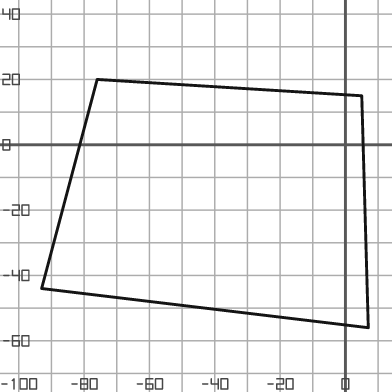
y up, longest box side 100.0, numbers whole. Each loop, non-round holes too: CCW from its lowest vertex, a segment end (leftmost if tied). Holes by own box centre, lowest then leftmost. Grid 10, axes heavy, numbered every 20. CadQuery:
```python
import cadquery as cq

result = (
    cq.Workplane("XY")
    .moveTo(7.0, -56.0)
    .lineTo(5.0, 15.0)
    .lineTo(-76.0, 20.0)
    .lineTo(-93.0, -44.0)
    .close()
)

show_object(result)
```